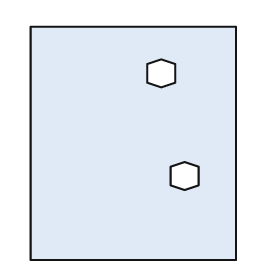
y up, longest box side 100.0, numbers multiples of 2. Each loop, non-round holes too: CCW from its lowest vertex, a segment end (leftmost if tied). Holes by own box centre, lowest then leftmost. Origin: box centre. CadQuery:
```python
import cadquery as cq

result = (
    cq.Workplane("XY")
    .moveTo(-44.0, -50.0)
    .lineTo(44.0, -50.0)
    .lineTo(44.0, 50.0)
    .lineTo(-44.0, 50.0)
    .close()
    .moveTo(22.0, -20.0)
    .lineTo(28.0, -18.0)
    .lineTo(28.0, -10.0)
    .lineTo(22.0, -8.0)
    .lineTo(16.0, -10.0)
    .lineTo(16.0, -18.0)
    .close()
    .moveTo(12.0, 24.0)
    .lineTo(18.0, 26.0)
    .lineTo(18.0, 34.0)
    .lineTo(12.0, 36.0)
    .lineTo(6.0, 34.0)
    .lineTo(6.0, 26.0)
    .close()
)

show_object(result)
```